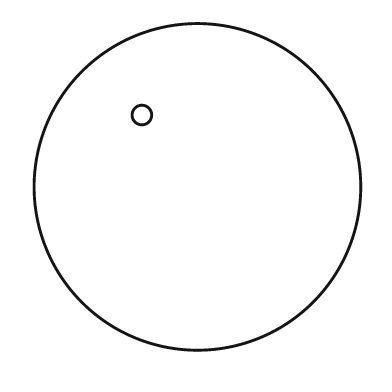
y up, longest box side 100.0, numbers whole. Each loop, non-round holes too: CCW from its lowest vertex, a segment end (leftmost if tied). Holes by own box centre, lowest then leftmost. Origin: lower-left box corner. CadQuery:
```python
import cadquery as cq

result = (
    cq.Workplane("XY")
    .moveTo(50.0, 50.0)
    .circle(50.0)
    .moveTo(33.0, 72.0)
    .circle(3.0)
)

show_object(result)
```